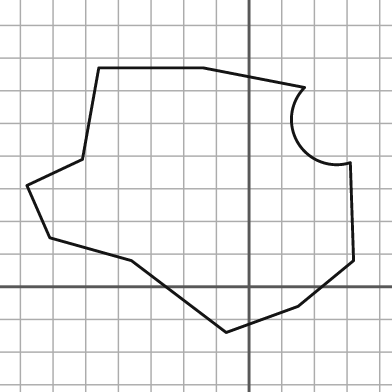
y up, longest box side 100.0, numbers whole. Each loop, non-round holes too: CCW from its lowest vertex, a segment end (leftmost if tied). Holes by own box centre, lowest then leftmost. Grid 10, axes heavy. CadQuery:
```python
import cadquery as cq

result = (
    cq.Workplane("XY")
    .moveTo(-7.0, -14.0)
    .lineTo(15.0, -6.0)
    .lineTo(32.0, 8.0)
    .lineTo(31.0, 38.0)
    .threePointArc((15.0, 44.0), (17.0, 61.0))
    .lineTo(-14.0, 67.0)
    .lineTo(-46.0, 67.0)
    .lineTo(-51.0, 39.0)
    .lineTo(-68.0, 31.0)
    .lineTo(-61.0, 15.0)
    .lineTo(-36.0, 8.0)
    .close()
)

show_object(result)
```